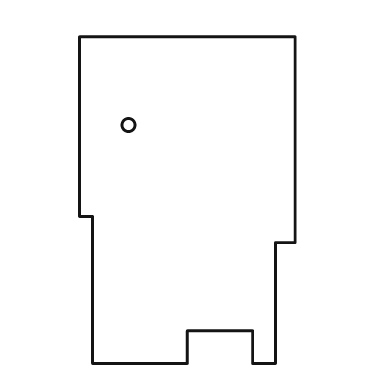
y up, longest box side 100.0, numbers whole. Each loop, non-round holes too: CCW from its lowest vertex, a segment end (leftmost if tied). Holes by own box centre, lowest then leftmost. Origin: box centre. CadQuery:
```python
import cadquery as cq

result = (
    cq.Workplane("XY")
    .moveTo(-29.0, -50.0)
    .lineTo(0.0, -50.0)
    .lineTo(0.0, -40.0)
    .lineTo(20.0, -40.0)
    .lineTo(20.0, -50.0)
    .lineTo(27.0, -50.0)
    .lineTo(27.0, -13.0)
    .lineTo(33.0, -13.0)
    .lineTo(33.0, 50.0)
    .lineTo(-33.0, 50.0)
    .lineTo(-33.0, -5.0)
    .lineTo(-29.0, -5.0)
    .close()
    .moveTo(-18.0, 23.0)
    .circle(2.0)
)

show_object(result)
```